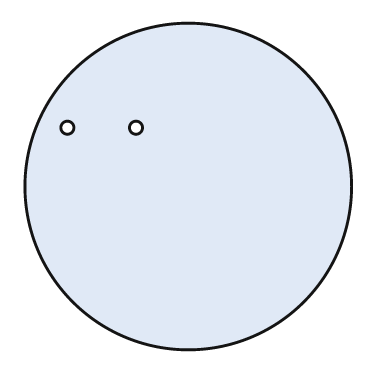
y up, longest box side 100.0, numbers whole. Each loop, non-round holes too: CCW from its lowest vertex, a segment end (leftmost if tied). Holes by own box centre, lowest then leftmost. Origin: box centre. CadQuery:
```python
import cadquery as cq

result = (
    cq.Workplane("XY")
    .moveTo(0.0, 0.0)
    .circle(50.0)
    .moveTo(-37.0, 18.0)
    .circle(2.0)
    .moveTo(-16.0, 18.0)
    .circle(2.0)
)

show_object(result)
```